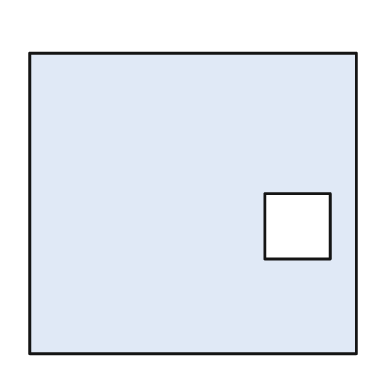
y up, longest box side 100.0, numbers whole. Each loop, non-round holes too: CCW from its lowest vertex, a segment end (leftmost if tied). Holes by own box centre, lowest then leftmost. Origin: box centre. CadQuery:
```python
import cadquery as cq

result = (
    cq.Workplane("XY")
    .moveTo(-50.0, -46.0)
    .lineTo(50.0, -46.0)
    .lineTo(50.0, 46.0)
    .lineTo(-50.0, 46.0)
    .close()
    .moveTo(22.0, -17.0)
    .lineTo(42.0, -17.0)
    .lineTo(42.0, 3.0)
    .lineTo(22.0, 3.0)
    .close()
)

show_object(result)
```